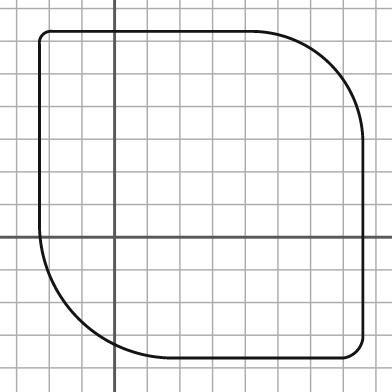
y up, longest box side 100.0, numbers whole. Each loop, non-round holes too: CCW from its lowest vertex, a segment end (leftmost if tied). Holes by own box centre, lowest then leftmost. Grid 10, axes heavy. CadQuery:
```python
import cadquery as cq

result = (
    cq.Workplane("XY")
    .moveTo(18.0, -37.0)
    .lineTo(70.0, -37.0)
    .threePointArc((74.0, -35.0), (76.0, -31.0))
    .lineTo(76.0, 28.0)
    .threePointArc((66.0, 53.0), (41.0, 63.0))
    .lineTo(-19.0, 63.0)
    .threePointArc((-22.0, 62.0), (-23.0, 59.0))
    .lineTo(-23.0, 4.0)
    .threePointArc((-11.0, -25.0), (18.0, -37.0))
    .close()
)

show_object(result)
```